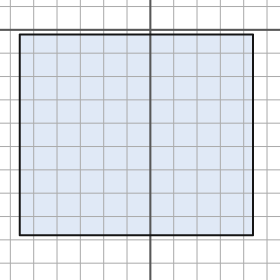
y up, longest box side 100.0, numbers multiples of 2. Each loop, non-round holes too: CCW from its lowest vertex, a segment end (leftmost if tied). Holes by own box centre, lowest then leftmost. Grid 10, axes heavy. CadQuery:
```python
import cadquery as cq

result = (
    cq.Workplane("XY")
    .moveTo(-56.0, -88.0)
    .lineTo(44.0, -88.0)
    .lineTo(44.0, -2.0)
    .lineTo(-56.0, -2.0)
    .close()
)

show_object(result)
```